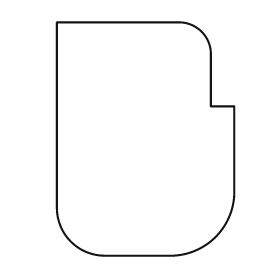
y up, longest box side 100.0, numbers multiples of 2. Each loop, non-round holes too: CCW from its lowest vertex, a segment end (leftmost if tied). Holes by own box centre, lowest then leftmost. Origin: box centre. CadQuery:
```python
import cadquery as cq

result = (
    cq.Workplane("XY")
    .moveTo(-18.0, -50.0)
    .lineTo(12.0, -50.0)
    .threePointArc((30.0, -42.0), (38.0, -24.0))
    .lineTo(38.0, 14.0)
    .lineTo(28.0, 14.0)
    .lineTo(28.0, 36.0)
    .threePointArc((24.0, 46.0), (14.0, 50.0))
    .lineTo(-38.0, 50.0)
    .lineTo(-38.0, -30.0)
    .threePointArc((-32.0, -44.0), (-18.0, -50.0))
    .close()
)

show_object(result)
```